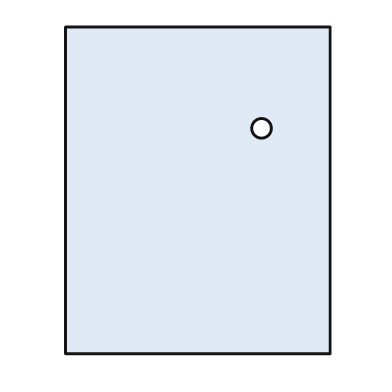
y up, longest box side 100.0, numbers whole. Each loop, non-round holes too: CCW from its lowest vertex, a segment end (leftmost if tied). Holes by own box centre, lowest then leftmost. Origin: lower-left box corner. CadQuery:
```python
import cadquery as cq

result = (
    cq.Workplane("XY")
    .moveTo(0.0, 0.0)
    .lineTo(81.0, 0.0)
    .lineTo(81.0, 100.0)
    .lineTo(0.0, 100.0)
    .close()
    .moveTo(60.0, 69.0)
    .circle(3.0)
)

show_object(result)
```